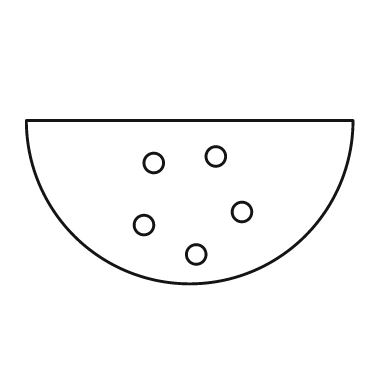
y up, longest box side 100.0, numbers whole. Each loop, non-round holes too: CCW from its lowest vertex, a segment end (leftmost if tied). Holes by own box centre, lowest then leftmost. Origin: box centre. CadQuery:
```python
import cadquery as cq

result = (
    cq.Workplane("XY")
    .moveTo(-50.0, 25.0)
    .threePointArc((0.0, -25.0), (50.0, 25.0))
    .close()
    .moveTo(2.0, -16.0)
    .circle(3.0)
    .moveTo(-14.0, -7.0)
    .circle(3.0)
    .moveTo(16.0, -3.0)
    .circle(3.0)
    .moveTo(-11.0, 12.0)
    .circle(3.0)
    .moveTo(8.0, 14.0)
    .circle(3.0)
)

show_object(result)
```